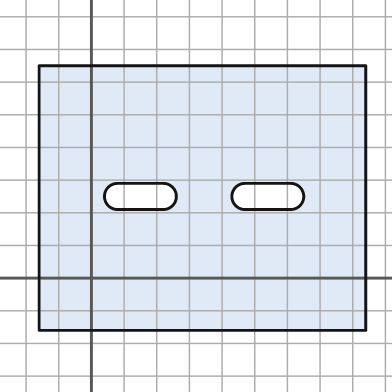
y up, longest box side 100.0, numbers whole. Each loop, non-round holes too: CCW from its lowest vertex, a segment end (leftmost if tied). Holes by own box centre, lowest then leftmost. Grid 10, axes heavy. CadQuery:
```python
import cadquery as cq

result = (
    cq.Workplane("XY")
    .moveTo(-16.0, -16.0)
    .lineTo(84.0, -16.0)
    .lineTo(84.0, 65.0)
    .lineTo(-16.0, 65.0)
    .close()
    .moveTo(8.0, 21.0)
    .lineTo(22.0, 21.0)
    .threePointArc((26.0, 25.0), (22.0, 29.0))
    .lineTo(8.0, 29.0)
    .threePointArc((4.0, 25.0), (8.0, 21.0))
    .close()
    .moveTo(47.0, 21.0)
    .lineTo(61.0, 21.0)
    .threePointArc((65.0, 25.0), (61.0, 29.0))
    .lineTo(47.0, 29.0)
    .threePointArc((43.0, 25.0), (47.0, 21.0))
    .close()
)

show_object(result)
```